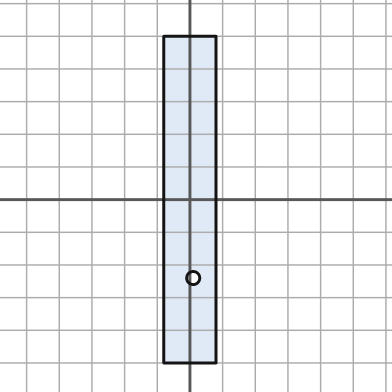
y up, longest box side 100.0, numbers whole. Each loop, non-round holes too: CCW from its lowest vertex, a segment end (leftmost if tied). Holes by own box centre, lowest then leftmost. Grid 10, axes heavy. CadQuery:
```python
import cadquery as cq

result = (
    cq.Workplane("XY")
    .moveTo(-8.0, -50.0)
    .lineTo(8.0, -50.0)
    .lineTo(8.0, 50.0)
    .lineTo(-8.0, 50.0)
    .close()
    .moveTo(1.0, -24.0)
    .circle(2.0)
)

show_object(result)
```